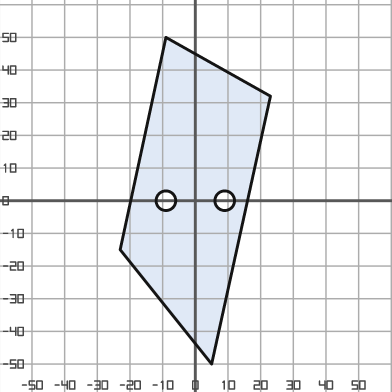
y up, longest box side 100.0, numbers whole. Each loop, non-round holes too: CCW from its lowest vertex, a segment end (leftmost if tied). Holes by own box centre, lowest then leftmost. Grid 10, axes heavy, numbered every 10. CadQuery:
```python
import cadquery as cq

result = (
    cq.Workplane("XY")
    .moveTo(5.0, -50.0)
    .lineTo(23.0, 32.0)
    .lineTo(-9.0, 50.0)
    .lineTo(-23.0, -15.0)
    .close()
    .moveTo(-9.0, 0.0)
    .circle(3.0)
    .moveTo(9.0, 0.0)
    .circle(3.0)
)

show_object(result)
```